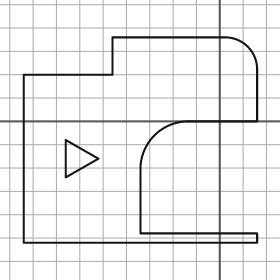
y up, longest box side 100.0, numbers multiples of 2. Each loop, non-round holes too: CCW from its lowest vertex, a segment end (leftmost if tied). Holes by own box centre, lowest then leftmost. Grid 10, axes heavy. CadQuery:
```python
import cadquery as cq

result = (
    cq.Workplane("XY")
    .moveTo(-84.0, -52.0)
    .lineTo(16.0, -52.0)
    .lineTo(16.0, -48.0)
    .lineTo(-34.0, -48.0)
    .lineTo(-34.0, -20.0)
    .threePointArc((-28.0, -6.0), (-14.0, 0.0))
    .lineTo(16.0, 0.0)
    .lineTo(16.0, 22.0)
    .threePointArc((12.0, 32.0), (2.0, 36.0))
    .lineTo(-46.0, 36.0)
    .lineTo(-46.0, 20.0)
    .lineTo(-84.0, 20.0)
    .close()
    .moveTo(-66.0, -24.0)
    .lineTo(-52.0, -16.0)
    .lineTo(-66.0, -8.0)
    .close()
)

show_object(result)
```